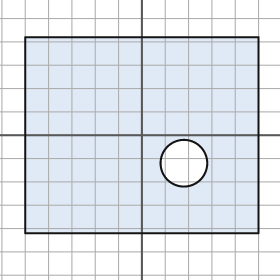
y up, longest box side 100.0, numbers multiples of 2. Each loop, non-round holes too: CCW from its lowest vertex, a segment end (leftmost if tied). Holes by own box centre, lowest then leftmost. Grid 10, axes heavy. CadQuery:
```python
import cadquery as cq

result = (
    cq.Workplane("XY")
    .moveTo(-50.0, -42.0)
    .lineTo(50.0, -42.0)
    .lineTo(50.0, 42.0)
    .lineTo(-50.0, 42.0)
    .close()
    .moveTo(18.0, -12.0)
    .circle(10.0)
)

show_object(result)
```